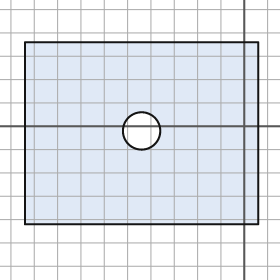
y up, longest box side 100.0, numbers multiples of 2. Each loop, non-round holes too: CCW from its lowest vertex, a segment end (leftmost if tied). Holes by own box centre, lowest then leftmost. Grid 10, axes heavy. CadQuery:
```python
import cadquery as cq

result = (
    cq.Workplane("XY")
    .moveTo(-94.0, -42.0)
    .lineTo(6.0, -42.0)
    .lineTo(6.0, 36.0)
    .lineTo(-94.0, 36.0)
    .close()
    .moveTo(-44.0, -2.0)
    .circle(8.0)
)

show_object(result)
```